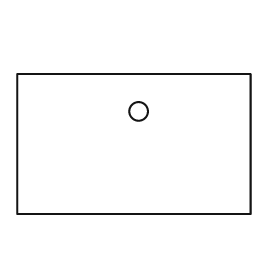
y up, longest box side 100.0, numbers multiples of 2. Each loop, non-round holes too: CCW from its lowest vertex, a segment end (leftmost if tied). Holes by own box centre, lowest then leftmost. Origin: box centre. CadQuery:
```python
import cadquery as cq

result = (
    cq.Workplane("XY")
    .moveTo(-50.0, -30.0)
    .lineTo(50.0, -30.0)
    .lineTo(50.0, 30.0)
    .lineTo(-50.0, 30.0)
    .close()
    .moveTo(2.0, 14.0)
    .circle(4.0)
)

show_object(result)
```